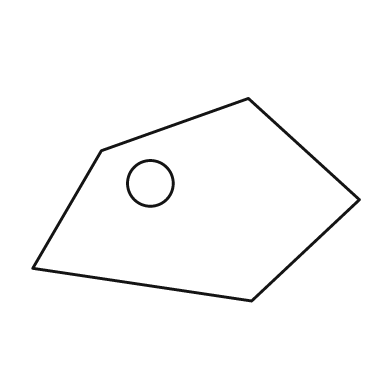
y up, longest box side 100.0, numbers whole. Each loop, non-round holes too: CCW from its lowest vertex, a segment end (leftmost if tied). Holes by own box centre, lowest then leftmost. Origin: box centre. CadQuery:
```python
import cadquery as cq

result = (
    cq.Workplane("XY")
    .moveTo(17.0, -31.0)
    .lineTo(50.0, 0.0)
    .lineTo(16.0, 31.0)
    .lineTo(-29.0, 15.0)
    .lineTo(-50.0, -21.0)
    .close()
    .moveTo(-14.0, 5.0)
    .circle(7.0)
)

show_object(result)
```